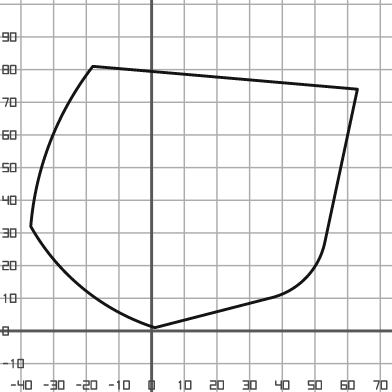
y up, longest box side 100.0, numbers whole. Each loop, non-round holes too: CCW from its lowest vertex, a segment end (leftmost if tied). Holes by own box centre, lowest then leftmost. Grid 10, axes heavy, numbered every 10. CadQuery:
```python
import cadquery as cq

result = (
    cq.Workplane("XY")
    .moveTo(1.0, 1.0)
    .lineTo(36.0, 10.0)
    .threePointArc((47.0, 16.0), (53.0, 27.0))
    .lineTo(63.0, 74.0)
    .lineTo(-18.0, 81.0)
    .threePointArc((-31.0, 58.0), (-37.0, 32.0))
    .threePointArc((-21.0, 13.0), (1.0, 1.0))
    .close()
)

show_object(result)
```